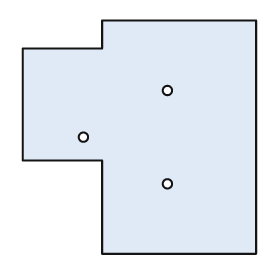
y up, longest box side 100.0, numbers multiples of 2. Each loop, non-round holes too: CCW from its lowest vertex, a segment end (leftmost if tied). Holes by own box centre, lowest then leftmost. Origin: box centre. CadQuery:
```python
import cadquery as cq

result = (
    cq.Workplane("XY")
    .moveTo(-16.0, -50.0)
    .lineTo(50.0, -50.0)
    .lineTo(50.0, 50.0)
    .lineTo(-16.0, 50.0)
    .lineTo(-16.0, 38.0)
    .lineTo(-50.0, 38.0)
    .lineTo(-50.0, -10.0)
    .lineTo(-16.0, -10.0)
    .close()
    .moveTo(12.0, -20.0)
    .circle(2.0)
    .moveTo(-24.0, 0.0)
    .circle(2.0)
    .moveTo(12.0, 20.0)
    .circle(2.0)
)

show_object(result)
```